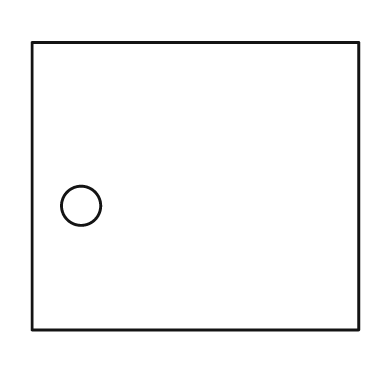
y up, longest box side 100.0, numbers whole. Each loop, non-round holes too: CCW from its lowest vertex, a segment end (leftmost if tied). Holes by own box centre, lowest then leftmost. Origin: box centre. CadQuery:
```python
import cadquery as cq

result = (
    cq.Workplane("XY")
    .moveTo(-50.0, -44.0)
    .lineTo(50.0, -44.0)
    .lineTo(50.0, 44.0)
    .lineTo(-50.0, 44.0)
    .close()
    .moveTo(-35.0, -6.0)
    .circle(6.0)
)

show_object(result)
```